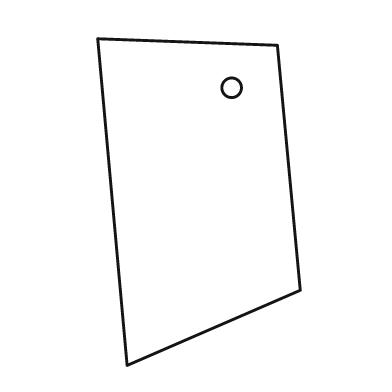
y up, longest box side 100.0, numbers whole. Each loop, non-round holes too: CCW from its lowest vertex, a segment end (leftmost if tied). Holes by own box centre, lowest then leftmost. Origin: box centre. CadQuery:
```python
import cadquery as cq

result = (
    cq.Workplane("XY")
    .moveTo(-22.0, -50.0)
    .lineTo(31.0, -27.0)
    .lineTo(24.0, 48.0)
    .lineTo(-31.0, 50.0)
    .close()
    .moveTo(10.0, 35.0)
    .circle(3.0)
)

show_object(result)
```